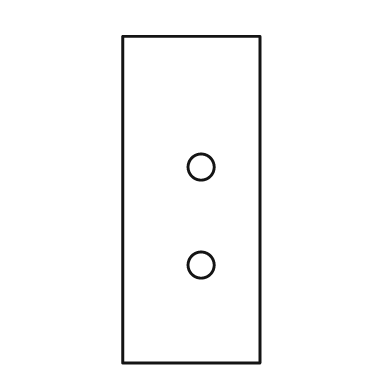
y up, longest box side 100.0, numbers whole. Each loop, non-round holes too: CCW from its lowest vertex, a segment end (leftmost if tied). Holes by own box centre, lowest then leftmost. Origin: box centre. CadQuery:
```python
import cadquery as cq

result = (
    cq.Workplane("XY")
    .moveTo(-21.0, -50.0)
    .lineTo(21.0, -50.0)
    .lineTo(21.0, 50.0)
    .lineTo(-21.0, 50.0)
    .close()
    .moveTo(3.0, -20.0)
    .circle(4.0)
    .moveTo(3.0, 10.0)
    .circle(4.0)
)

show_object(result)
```